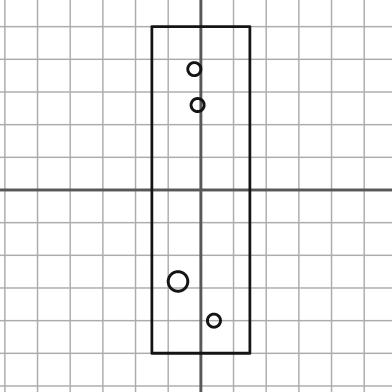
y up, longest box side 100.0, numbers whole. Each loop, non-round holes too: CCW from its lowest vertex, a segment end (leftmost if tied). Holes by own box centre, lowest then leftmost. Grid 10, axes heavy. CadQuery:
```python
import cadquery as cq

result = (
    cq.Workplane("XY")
    .moveTo(-15.0, -50.0)
    .lineTo(15.0, -50.0)
    .lineTo(15.0, 50.0)
    .lineTo(-15.0, 50.0)
    .close()
    .moveTo(4.0, -40.0)
    .circle(2.0)
    .moveTo(-7.0, -28.0)
    .circle(3.0)
    .moveTo(-1.0, 26.0)
    .circle(2.0)
    .moveTo(-2.0, 37.0)
    .circle(2.0)
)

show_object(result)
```